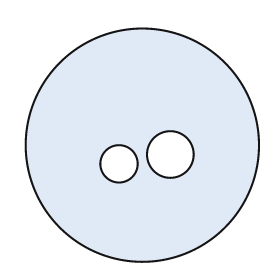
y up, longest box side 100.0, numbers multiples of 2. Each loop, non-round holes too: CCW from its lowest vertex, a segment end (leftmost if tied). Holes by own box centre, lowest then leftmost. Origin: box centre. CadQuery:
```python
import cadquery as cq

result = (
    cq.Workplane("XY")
    .moveTo(0.0, 0.0)
    .circle(50.0)
    .moveTo(-10.0, -8.0)
    .circle(8.0)
    .moveTo(12.0, -4.0)
    .circle(10.0)
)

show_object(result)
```